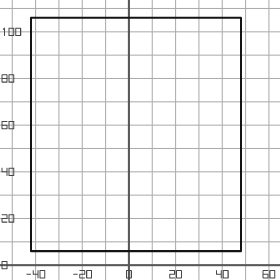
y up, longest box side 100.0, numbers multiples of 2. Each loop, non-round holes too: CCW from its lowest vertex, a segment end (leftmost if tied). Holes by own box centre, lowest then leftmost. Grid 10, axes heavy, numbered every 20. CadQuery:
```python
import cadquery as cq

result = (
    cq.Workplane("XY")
    .moveTo(-42.0, 6.0)
    .lineTo(48.0, 6.0)
    .lineTo(48.0, 106.0)
    .lineTo(-42.0, 106.0)
    .close()
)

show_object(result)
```